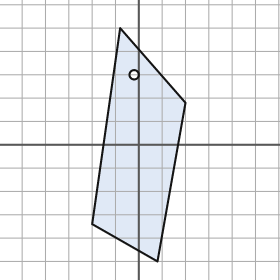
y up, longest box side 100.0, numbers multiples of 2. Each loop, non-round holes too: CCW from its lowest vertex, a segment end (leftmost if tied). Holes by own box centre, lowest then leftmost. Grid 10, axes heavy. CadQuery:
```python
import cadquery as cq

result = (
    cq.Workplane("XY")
    .moveTo(8.0, -50.0)
    .lineTo(20.0, 18.0)
    .lineTo(-8.0, 50.0)
    .lineTo(-20.0, -34.0)
    .close()
    .moveTo(-2.0, 30.0)
    .circle(2.0)
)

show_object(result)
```